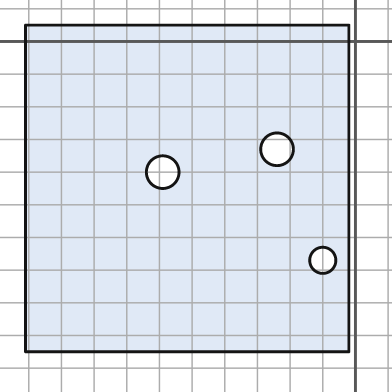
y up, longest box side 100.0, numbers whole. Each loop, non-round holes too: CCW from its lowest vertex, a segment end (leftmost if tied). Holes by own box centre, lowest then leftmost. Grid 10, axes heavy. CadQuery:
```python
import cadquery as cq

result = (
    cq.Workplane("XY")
    .moveTo(-101.0, -95.0)
    .lineTo(-2.0, -95.0)
    .lineTo(-2.0, 5.0)
    .lineTo(-101.0, 5.0)
    .close()
    .moveTo(-10.0, -67.0)
    .circle(4.0)
    .moveTo(-59.0, -40.0)
    .circle(5.0)
    .moveTo(-24.0, -33.0)
    .circle(5.0)
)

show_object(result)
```